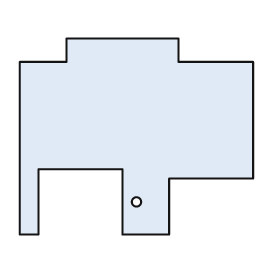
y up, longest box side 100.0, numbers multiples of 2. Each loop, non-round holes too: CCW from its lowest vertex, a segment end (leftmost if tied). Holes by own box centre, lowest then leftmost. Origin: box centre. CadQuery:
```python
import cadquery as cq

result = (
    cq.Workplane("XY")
    .moveTo(-50.0, -42.0)
    .lineTo(-42.0, -42.0)
    .lineTo(-42.0, -14.0)
    .lineTo(-6.0, -14.0)
    .lineTo(-6.0, -42.0)
    .lineTo(14.0, -42.0)
    .lineTo(14.0, -18.0)
    .lineTo(50.0, -18.0)
    .lineTo(50.0, 32.0)
    .lineTo(18.0, 32.0)
    .lineTo(18.0, 42.0)
    .lineTo(-30.0, 42.0)
    .lineTo(-30.0, 32.0)
    .lineTo(-50.0, 32.0)
    .close()
    .moveTo(0.0, -28.0)
    .circle(2.0)
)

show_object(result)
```